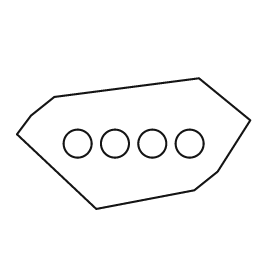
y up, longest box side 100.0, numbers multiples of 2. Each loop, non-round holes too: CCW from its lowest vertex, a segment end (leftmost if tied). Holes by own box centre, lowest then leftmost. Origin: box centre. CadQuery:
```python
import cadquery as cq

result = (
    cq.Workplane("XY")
    .moveTo(-16.0, -28.0)
    .lineTo(26.0, -20.0)
    .lineTo(36.0, -12.0)
    .lineTo(50.0, 10.0)
    .lineTo(28.0, 28.0)
    .lineTo(-34.0, 20.0)
    .lineTo(-44.0, 12.0)
    .lineTo(-50.0, 4.0)
    .close()
    .moveTo(-24.0, 0.0)
    .circle(6.0)
    .moveTo(-8.0, 0.0)
    .circle(6.0)
    .moveTo(8.0, 0.0)
    .circle(6.0)
    .moveTo(24.0, 0.0)
    .circle(6.0)
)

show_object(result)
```